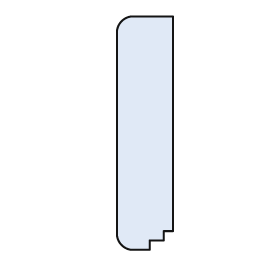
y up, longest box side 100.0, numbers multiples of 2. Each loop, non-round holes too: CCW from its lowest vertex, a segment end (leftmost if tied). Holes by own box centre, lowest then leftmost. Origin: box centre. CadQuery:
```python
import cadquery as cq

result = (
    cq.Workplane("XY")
    .moveTo(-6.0, -50.0)
    .lineTo(2.0, -50.0)
    .lineTo(2.0, -46.0)
    .lineTo(8.0, -46.0)
    .lineTo(8.0, -42.0)
    .lineTo(12.0, -42.0)
    .lineTo(12.0, 50.0)
    .lineTo(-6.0, 50.0)
    .threePointArc((-10.0, 48.0), (-12.0, 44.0))
    .lineTo(-12.0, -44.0)
    .threePointArc((-10.0, -48.0), (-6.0, -50.0))
    .close()
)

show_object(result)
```